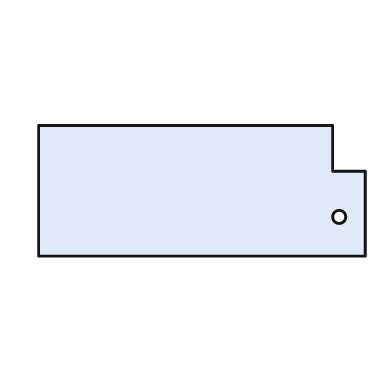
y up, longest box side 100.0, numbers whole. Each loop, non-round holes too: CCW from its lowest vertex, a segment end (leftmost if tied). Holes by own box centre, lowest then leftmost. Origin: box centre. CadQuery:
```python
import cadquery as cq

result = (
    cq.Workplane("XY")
    .moveTo(-50.0, -20.0)
    .lineTo(50.0, -20.0)
    .lineTo(50.0, 6.0)
    .lineTo(40.0, 6.0)
    .lineTo(40.0, 20.0)
    .lineTo(-50.0, 20.0)
    .close()
    .moveTo(42.0, -8.0)
    .circle(2.0)
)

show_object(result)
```